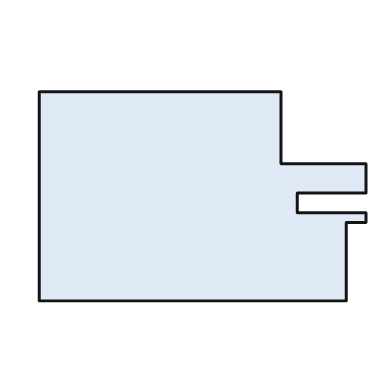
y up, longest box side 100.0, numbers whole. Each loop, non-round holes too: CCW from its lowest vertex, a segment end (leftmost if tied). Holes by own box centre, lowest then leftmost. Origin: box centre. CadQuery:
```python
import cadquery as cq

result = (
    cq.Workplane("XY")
    .moveTo(-50.0, -32.0)
    .lineTo(44.0, -32.0)
    .lineTo(44.0, -8.0)
    .lineTo(50.0, -8.0)
    .lineTo(50.0, -5.0)
    .lineTo(29.0, -5.0)
    .lineTo(29.0, 1.0)
    .lineTo(50.0, 1.0)
    .lineTo(50.0, 10.0)
    .lineTo(24.0, 10.0)
    .lineTo(24.0, 32.0)
    .lineTo(-50.0, 32.0)
    .close()
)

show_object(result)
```